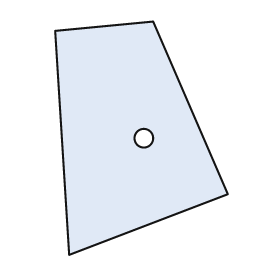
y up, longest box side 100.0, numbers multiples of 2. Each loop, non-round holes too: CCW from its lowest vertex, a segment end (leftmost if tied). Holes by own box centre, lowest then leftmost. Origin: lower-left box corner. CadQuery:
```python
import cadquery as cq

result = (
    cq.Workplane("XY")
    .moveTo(6.0, 0.0)
    .lineTo(74.0, 26.0)
    .lineTo(42.0, 100.0)
    .lineTo(0.0, 96.0)
    .close()
    .moveTo(38.0, 50.0)
    .circle(4.0)
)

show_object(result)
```